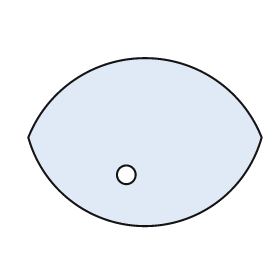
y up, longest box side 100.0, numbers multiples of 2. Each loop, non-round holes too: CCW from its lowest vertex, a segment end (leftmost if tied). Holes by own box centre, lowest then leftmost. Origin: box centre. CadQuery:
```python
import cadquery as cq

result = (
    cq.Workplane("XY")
    .moveTo(-50.0, 2.0)
    .threePointArc((0.0, -36.0), (50.0, 2.0))
    .threePointArc((0.0, 36.0), (-50.0, 2.0))
    .close()
    .moveTo(-8.0, -14.0)
    .circle(4.0)
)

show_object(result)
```